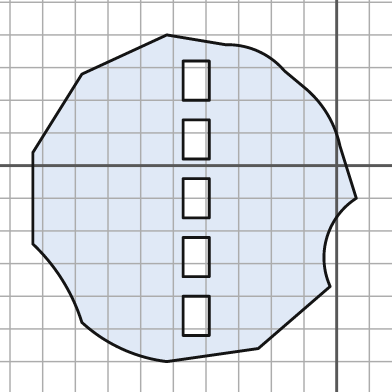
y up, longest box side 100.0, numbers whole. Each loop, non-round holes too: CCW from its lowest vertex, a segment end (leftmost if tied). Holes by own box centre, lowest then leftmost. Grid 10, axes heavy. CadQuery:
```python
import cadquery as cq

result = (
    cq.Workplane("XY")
    .moveTo(-52.0, -60.0)
    .lineTo(-24.0, -56.0)
    .lineTo(-2.0, -37.0)
    .threePointArc((-3.0, -22.0), (6.0, -10.0))
    .lineTo(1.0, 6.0)
    .threePointArc((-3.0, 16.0), (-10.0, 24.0))
    .lineTo(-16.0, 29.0)
    .threePointArc((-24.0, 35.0), (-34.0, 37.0))
    .lineTo(-52.0, 40.0)
    .lineTo(-78.0, 28.0)
    .lineTo(-93.0, 4.0)
    .lineTo(-93.0, -24.0)
    .threePointArc((-84.0, -35.0), (-78.0, -48.0))
    .threePointArc((-66.0, -56.0), (-52.0, -60.0))
    .close()
    .moveTo(-47.0, -52.0)
    .lineTo(-39.0, -52.0)
    .lineTo(-39.0, -40.0)
    .lineTo(-47.0, -40.0)
    .close()
    .moveTo(-47.0, -34.0)
    .lineTo(-39.0, -34.0)
    .lineTo(-39.0, -22.0)
    .lineTo(-47.0, -22.0)
    .close()
    .moveTo(-47.0, -16.0)
    .lineTo(-39.0, -16.0)
    .lineTo(-39.0, -4.0)
    .lineTo(-47.0, -4.0)
    .close()
    .moveTo(-47.0, 2.0)
    .lineTo(-39.0, 2.0)
    .lineTo(-39.0, 14.0)
    .lineTo(-47.0, 14.0)
    .close()
    .moveTo(-47.0, 20.0)
    .lineTo(-39.0, 20.0)
    .lineTo(-39.0, 32.0)
    .lineTo(-47.0, 32.0)
    .close()
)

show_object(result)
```